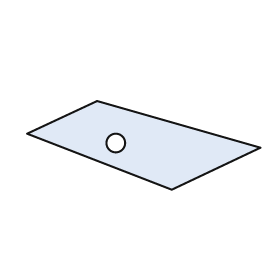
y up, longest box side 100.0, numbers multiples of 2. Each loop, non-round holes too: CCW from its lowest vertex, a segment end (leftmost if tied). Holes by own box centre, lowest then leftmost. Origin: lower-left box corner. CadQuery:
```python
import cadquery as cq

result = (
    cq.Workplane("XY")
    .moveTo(62.0, 0.0)
    .lineTo(100.0, 18.0)
    .lineTo(30.0, 38.0)
    .lineTo(0.0, 24.0)
    .close()
    .moveTo(38.0, 20.0)
    .circle(4.0)
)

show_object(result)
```